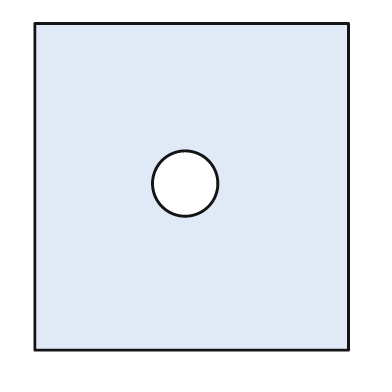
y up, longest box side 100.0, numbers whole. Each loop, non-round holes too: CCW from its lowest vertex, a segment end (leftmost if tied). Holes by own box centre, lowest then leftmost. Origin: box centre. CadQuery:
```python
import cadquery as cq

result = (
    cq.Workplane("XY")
    .moveTo(-48.0, -50.0)
    .lineTo(48.0, -50.0)
    .lineTo(48.0, 50.0)
    .lineTo(-48.0, 50.0)
    .close()
    .moveTo(-2.0, 1.0)
    .circle(10.0)
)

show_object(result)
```